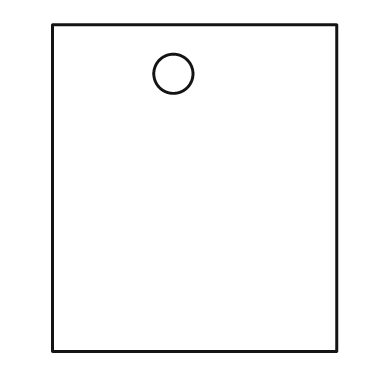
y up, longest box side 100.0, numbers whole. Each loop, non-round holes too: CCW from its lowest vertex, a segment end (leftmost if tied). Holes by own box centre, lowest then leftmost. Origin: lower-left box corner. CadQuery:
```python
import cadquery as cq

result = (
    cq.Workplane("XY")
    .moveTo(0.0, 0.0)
    .lineTo(87.0, 0.0)
    .lineTo(87.0, 100.0)
    .lineTo(0.0, 100.0)
    .close()
    .moveTo(37.0, 85.0)
    .circle(6.0)
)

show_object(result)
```